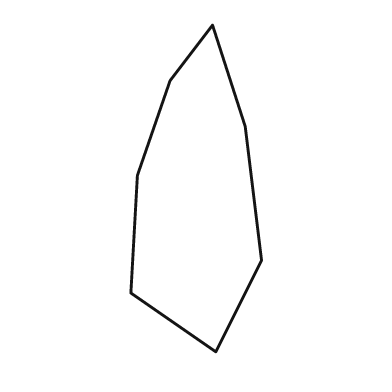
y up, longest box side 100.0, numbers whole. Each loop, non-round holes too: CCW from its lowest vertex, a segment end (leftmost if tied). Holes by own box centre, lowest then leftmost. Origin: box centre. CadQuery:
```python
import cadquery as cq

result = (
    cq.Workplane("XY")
    .moveTo(6.0, -50.0)
    .lineTo(20.0, -22.0)
    .lineTo(15.0, 19.0)
    .lineTo(5.0, 50.0)
    .lineTo(-8.0, 33.0)
    .lineTo(-18.0, 4.0)
    .lineTo(-20.0, -32.0)
    .close()
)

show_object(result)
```